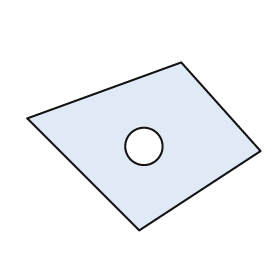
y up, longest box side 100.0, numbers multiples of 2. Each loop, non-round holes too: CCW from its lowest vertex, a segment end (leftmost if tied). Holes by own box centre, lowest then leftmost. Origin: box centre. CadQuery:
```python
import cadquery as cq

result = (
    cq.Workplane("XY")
    .moveTo(-2.0, -36.0)
    .lineTo(50.0, -2.0)
    .lineTo(16.0, 36.0)
    .lineTo(-50.0, 12.0)
    .close()
    .moveTo(0.0, 0.0)
    .circle(8.0)
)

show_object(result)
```